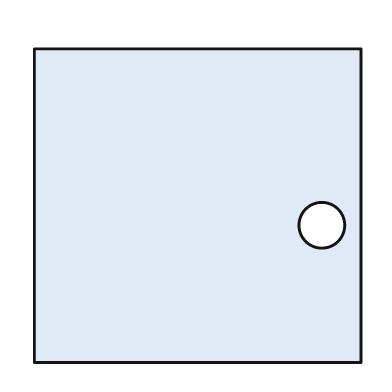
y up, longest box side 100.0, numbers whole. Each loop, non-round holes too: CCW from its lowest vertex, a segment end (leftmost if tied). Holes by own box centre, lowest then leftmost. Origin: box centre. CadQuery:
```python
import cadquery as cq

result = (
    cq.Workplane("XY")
    .moveTo(-50.0, -48.0)
    .lineTo(50.0, -48.0)
    .lineTo(50.0, 48.0)
    .lineTo(-50.0, 48.0)
    .close()
    .moveTo(38.0, -6.0)
    .circle(7.0)
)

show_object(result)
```